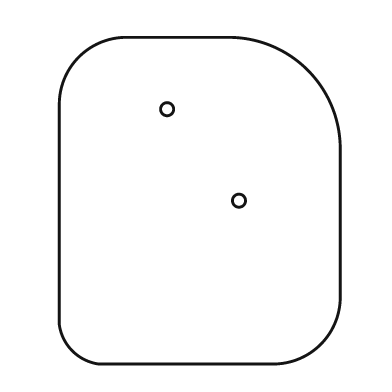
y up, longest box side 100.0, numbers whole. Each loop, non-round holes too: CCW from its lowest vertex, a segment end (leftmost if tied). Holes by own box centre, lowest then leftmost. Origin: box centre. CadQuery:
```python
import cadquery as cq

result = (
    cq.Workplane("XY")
    .moveTo(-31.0, -50.0)
    .lineTo(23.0, -50.0)
    .threePointArc((37.0, -44.0), (43.0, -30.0))
    .lineTo(43.0, 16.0)
    .threePointArc((33.0, 40.0), (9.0, 50.0))
    .lineTo(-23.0, 50.0)
    .threePointArc((-37.0, 44.0), (-43.0, 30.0))
    .lineTo(-43.0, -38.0)
    .threePointArc((-39.0, -46.0), (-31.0, -50.0))
    .close()
    .moveTo(12.0, 0.0)
    .circle(2.0)
    .moveTo(-10.0, 28.0)
    .circle(2.0)
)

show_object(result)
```